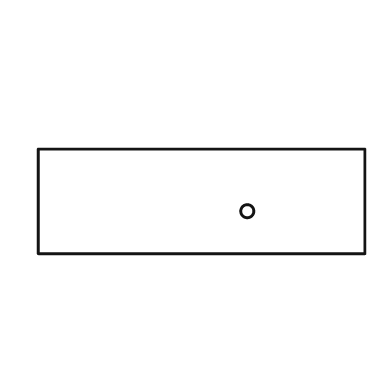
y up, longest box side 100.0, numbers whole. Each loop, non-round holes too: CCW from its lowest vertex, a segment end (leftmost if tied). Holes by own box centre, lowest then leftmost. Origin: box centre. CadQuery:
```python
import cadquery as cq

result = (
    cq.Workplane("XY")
    .moveTo(-50.0, -16.0)
    .lineTo(50.0, -16.0)
    .lineTo(50.0, 16.0)
    .lineTo(-50.0, 16.0)
    .close()
    .moveTo(14.0, -3.0)
    .circle(2.0)
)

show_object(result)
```